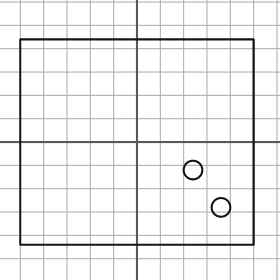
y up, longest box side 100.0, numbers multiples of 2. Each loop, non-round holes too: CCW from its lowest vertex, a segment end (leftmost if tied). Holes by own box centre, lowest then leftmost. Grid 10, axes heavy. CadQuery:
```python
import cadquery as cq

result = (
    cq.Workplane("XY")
    .moveTo(-50.0, -44.0)
    .lineTo(50.0, -44.0)
    .lineTo(50.0, 44.0)
    .lineTo(-50.0, 44.0)
    .close()
    .moveTo(36.0, -28.0)
    .circle(4.0)
    .moveTo(24.0, -12.0)
    .circle(4.0)
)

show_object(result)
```